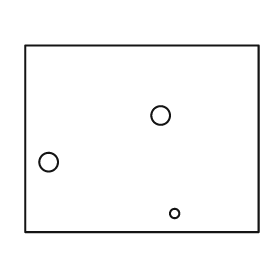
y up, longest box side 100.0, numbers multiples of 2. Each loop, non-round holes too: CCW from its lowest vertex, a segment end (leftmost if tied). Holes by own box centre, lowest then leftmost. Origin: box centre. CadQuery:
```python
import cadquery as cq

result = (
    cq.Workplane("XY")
    .moveTo(-50.0, -40.0)
    .lineTo(50.0, -40.0)
    .lineTo(50.0, 40.0)
    .lineTo(-50.0, 40.0)
    .close()
    .moveTo(14.0, -32.0)
    .circle(2.0)
    .moveTo(-40.0, -10.0)
    .circle(4.0)
    .moveTo(8.0, 10.0)
    .circle(4.0)
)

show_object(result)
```